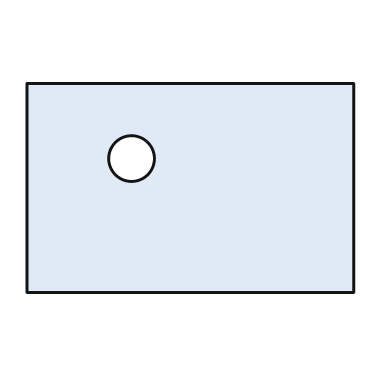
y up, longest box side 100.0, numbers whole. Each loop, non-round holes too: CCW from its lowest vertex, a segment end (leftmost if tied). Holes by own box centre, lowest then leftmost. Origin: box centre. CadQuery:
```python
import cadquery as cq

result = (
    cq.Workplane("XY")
    .moveTo(-50.0, -32.0)
    .lineTo(50.0, -32.0)
    .lineTo(50.0, 32.0)
    .lineTo(-50.0, 32.0)
    .close()
    .moveTo(-18.0, 9.0)
    .circle(7.0)
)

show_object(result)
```